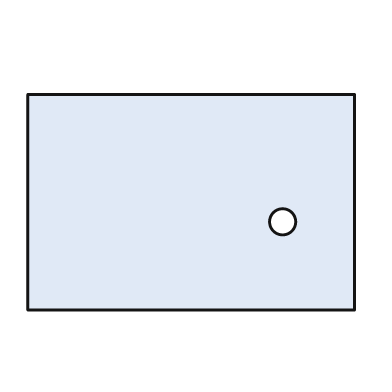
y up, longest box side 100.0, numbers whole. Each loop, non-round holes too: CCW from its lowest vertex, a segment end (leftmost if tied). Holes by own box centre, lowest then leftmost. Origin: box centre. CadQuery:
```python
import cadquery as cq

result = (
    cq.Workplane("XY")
    .moveTo(-50.0, -33.0)
    .lineTo(50.0, -33.0)
    .lineTo(50.0, 33.0)
    .lineTo(-50.0, 33.0)
    .close()
    .moveTo(28.0, -6.0)
    .circle(4.0)
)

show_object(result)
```